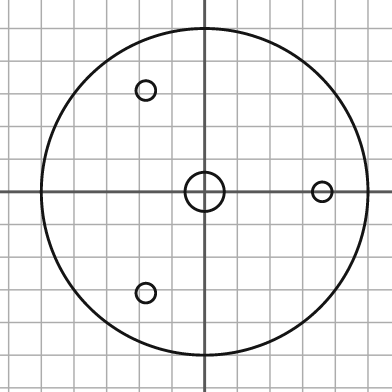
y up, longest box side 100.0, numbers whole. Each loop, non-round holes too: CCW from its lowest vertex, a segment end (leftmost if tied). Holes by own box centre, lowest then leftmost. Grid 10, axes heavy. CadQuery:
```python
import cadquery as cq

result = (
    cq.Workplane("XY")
    .moveTo(0.0, 0.0)
    .circle(50.0)
    .moveTo(-18.0, -31.0)
    .circle(3.0)
    .moveTo(0.0, 0.0)
    .circle(6.0)
    .moveTo(36.0, 0.0)
    .circle(3.0)
    .moveTo(-18.0, 31.0)
    .circle(3.0)
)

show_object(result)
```